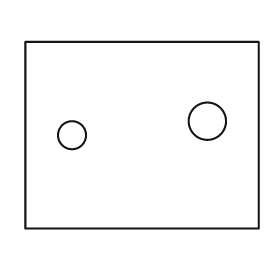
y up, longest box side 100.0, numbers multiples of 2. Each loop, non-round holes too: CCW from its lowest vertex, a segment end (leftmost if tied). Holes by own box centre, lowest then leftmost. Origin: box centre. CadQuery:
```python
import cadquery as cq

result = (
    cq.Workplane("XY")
    .moveTo(-50.0, -40.0)
    .lineTo(50.0, -40.0)
    .lineTo(50.0, 40.0)
    .lineTo(-50.0, 40.0)
    .close()
    .moveTo(-30.0, 0.0)
    .circle(6.0)
    .moveTo(28.0, 6.0)
    .circle(8.0)
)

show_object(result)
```